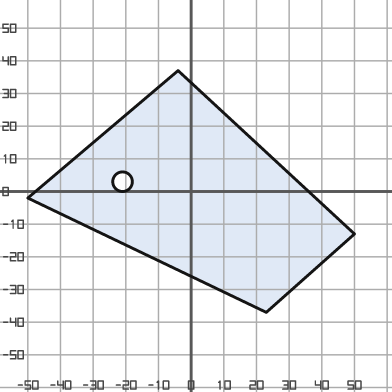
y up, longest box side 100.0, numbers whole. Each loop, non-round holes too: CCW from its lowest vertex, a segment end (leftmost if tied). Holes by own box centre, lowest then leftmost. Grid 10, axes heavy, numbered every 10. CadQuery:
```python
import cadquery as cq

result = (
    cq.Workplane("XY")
    .moveTo(23.0, -37.0)
    .lineTo(50.0, -13.0)
    .lineTo(-4.0, 37.0)
    .lineTo(-50.0, -2.0)
    .close()
    .moveTo(-21.0, 3.0)
    .circle(3.0)
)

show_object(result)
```